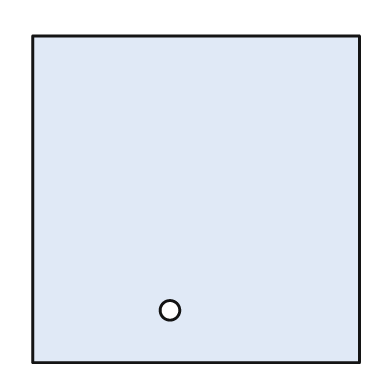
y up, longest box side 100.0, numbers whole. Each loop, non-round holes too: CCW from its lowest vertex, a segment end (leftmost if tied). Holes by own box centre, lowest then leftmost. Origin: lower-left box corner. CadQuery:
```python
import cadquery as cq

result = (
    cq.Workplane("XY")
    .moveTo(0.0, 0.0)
    .lineTo(100.0, 0.0)
    .lineTo(100.0, 100.0)
    .lineTo(0.0, 100.0)
    .close()
    .moveTo(42.0, 16.0)
    .circle(3.0)
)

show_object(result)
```